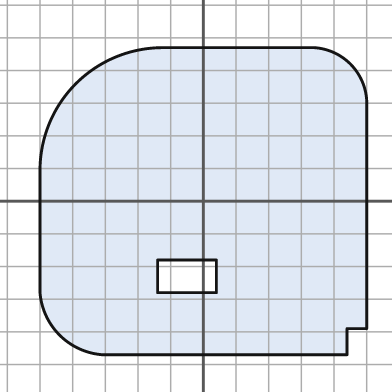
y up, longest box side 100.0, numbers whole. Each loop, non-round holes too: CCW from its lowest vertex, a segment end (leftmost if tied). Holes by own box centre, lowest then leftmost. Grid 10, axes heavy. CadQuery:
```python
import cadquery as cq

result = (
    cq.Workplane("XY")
    .moveTo(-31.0, -47.0)
    .lineTo(44.0, -47.0)
    .lineTo(44.0, -39.0)
    .lineTo(50.0, -39.0)
    .lineTo(50.0, 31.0)
    .threePointArc((45.0, 42.0), (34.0, 47.0))
    .lineTo(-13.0, 47.0)
    .threePointArc((-39.0, 36.0), (-50.0, 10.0))
    .lineTo(-50.0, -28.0)
    .threePointArc((-44.0, -41.0), (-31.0, -47.0))
    .close()
    .moveTo(-14.0, -28.0)
    .lineTo(4.0, -28.0)
    .lineTo(4.0, -18.0)
    .lineTo(-14.0, -18.0)
    .close()
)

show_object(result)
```